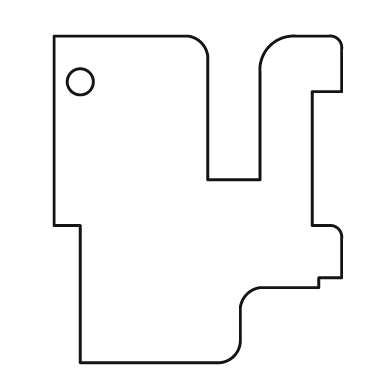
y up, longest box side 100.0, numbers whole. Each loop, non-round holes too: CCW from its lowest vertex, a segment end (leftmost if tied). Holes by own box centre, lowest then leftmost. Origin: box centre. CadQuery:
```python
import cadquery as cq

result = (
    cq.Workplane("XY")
    .moveTo(-36.0, -50.0)
    .lineTo(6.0, -50.0)
    .threePointArc((11.0, -48.0), (13.0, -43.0))
    .lineTo(13.0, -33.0)
    .threePointArc((15.0, -29.0), (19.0, -27.0))
    .lineTo(37.0, -27.0)
    .lineTo(37.0, -24.0)
    .lineTo(44.0, -24.0)
    .lineTo(44.0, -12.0)
    .threePointArc((43.0, -9.0), (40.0, -8.0))
    .lineTo(35.0, -8.0)
    .lineTo(35.0, 33.0)
    .lineTo(44.0, 33.0)
    .lineTo(44.0, 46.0)
    .threePointArc((43.0, 49.0), (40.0, 50.0))
    .lineTo(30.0, 50.0)
    .threePointArc((22.0, 47.0), (19.0, 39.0))
    .lineTo(19.0, 6.0)
    .lineTo(3.0, 6.0)
    .lineTo(3.0, 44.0)
    .threePointArc((1.0, 48.0), (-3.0, 50.0))
    .lineTo(-44.0, 50.0)
    .lineTo(-44.0, -8.0)
    .lineTo(-36.0, -8.0)
    .close()
    .moveTo(-36.0, 36.0)
    .circle(4.0)
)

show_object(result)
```